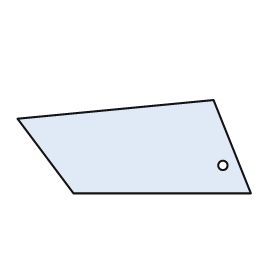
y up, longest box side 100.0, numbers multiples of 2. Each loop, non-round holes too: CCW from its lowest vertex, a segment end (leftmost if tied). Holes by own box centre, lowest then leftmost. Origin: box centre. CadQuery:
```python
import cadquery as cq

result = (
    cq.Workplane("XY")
    .moveTo(-26.0, -20.0)
    .lineTo(50.0, -20.0)
    .lineTo(34.0, 20.0)
    .lineTo(-50.0, 12.0)
    .close()
    .moveTo(38.0, -8.0)
    .circle(2.0)
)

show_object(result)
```